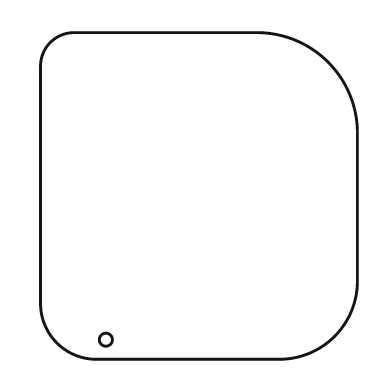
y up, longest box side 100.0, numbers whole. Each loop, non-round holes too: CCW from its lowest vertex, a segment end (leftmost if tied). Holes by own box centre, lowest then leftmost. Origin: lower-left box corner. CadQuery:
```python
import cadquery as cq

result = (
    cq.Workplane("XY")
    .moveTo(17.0, 0.0)
    .lineTo(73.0, 0.0)
    .threePointArc((90.0, 7.0), (97.0, 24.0))
    .lineTo(97.0, 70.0)
    .threePointArc((88.0, 91.0), (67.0, 100.0))
    .lineTo(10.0, 100.0)
    .threePointArc((3.0, 97.0), (0.0, 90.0))
    .lineTo(0.0, 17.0)
    .threePointArc((5.0, 5.0), (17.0, 0.0))
    .close()
    .moveTo(20.0, 6.0)
    .circle(2.0)
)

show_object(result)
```